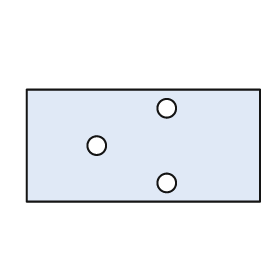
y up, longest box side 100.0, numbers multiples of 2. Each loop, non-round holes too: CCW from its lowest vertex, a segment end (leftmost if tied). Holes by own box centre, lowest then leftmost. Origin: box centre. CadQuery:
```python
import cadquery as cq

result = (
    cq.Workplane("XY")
    .moveTo(-50.0, -24.0)
    .lineTo(50.0, -24.0)
    .lineTo(50.0, 24.0)
    .lineTo(-50.0, 24.0)
    .close()
    .moveTo(10.0, -16.0)
    .circle(4.0)
    .moveTo(-20.0, 0.0)
    .circle(4.0)
    .moveTo(10.0, 16.0)
    .circle(4.0)
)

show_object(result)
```